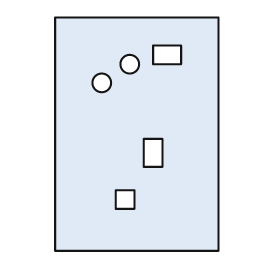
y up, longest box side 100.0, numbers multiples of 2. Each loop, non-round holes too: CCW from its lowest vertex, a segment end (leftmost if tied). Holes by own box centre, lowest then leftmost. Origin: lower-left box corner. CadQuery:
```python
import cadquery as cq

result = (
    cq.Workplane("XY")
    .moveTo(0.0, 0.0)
    .lineTo(70.0, 0.0)
    .lineTo(70.0, 100.0)
    .lineTo(0.0, 100.0)
    .close()
    .moveTo(26.0, 18.0)
    .lineTo(34.0, 18.0)
    .lineTo(34.0, 26.0)
    .lineTo(26.0, 26.0)
    .close()
    .moveTo(38.0, 36.0)
    .lineTo(46.0, 36.0)
    .lineTo(46.0, 48.0)
    .lineTo(38.0, 48.0)
    .close()
    .moveTo(20.0, 72.0)
    .circle(4.0)
    .moveTo(32.0, 80.0)
    .circle(4.0)
    .moveTo(42.0, 80.0)
    .lineTo(54.0, 80.0)
    .lineTo(54.0, 88.0)
    .lineTo(42.0, 88.0)
    .close()
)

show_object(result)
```